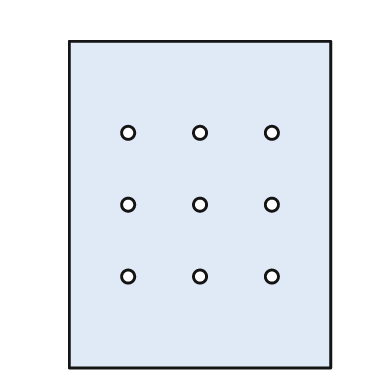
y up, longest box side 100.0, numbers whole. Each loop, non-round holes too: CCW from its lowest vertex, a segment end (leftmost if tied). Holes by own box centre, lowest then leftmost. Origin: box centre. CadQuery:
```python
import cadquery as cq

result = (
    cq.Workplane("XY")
    .moveTo(-40.0, -50.0)
    .lineTo(40.0, -50.0)
    .lineTo(40.0, 50.0)
    .lineTo(-40.0, 50.0)
    .close()
    .moveTo(-22.0, -22.0)
    .circle(2.0)
    .moveTo(0.0, -22.0)
    .circle(2.0)
    .moveTo(22.0, -22.0)
    .circle(2.0)
    .moveTo(-22.0, 0.0)
    .circle(2.0)
    .moveTo(0.0, 0.0)
    .circle(2.0)
    .moveTo(22.0, 0.0)
    .circle(2.0)
    .moveTo(-22.0, 22.0)
    .circle(2.0)
    .moveTo(0.0, 22.0)
    .circle(2.0)
    .moveTo(22.0, 22.0)
    .circle(2.0)
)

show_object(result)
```